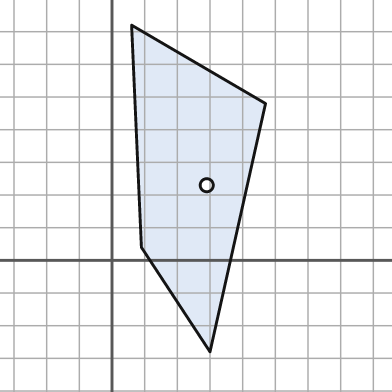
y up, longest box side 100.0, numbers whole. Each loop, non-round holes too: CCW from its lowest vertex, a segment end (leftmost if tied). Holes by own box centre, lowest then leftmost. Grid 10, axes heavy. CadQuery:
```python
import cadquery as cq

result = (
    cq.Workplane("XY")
    .moveTo(30.0, -28.0)
    .lineTo(47.0, 48.0)
    .lineTo(6.0, 72.0)
    .lineTo(9.0, 4.0)
    .close()
    .moveTo(29.0, 23.0)
    .circle(2.0)
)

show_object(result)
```